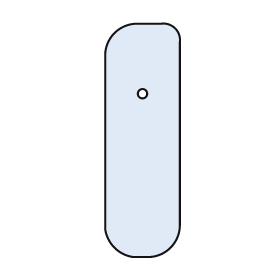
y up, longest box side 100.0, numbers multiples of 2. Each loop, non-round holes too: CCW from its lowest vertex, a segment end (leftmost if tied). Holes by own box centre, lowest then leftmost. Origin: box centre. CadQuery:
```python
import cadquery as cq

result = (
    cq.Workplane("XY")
    .moveTo(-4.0, -50.0)
    .lineTo(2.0, -50.0)
    .threePointArc((12.0, -46.0), (16.0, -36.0))
    .lineTo(16.0, 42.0)
    .threePointArc((14.0, 48.0), (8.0, 50.0))
    .lineTo(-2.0, 50.0)
    .threePointArc((-12.0, 46.0), (-16.0, 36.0))
    .lineTo(-16.0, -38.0)
    .threePointArc((-12.0, -46.0), (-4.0, -50.0))
    .close()
    .moveTo(0.0, 20.0)
    .circle(2.0)
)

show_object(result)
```